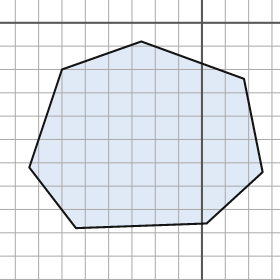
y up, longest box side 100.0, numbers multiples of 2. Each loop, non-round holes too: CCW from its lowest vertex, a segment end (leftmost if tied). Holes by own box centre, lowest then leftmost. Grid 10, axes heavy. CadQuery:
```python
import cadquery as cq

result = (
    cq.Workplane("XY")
    .moveTo(-54.0, -88.0)
    .lineTo(2.0, -86.0)
    .lineTo(26.0, -64.0)
    .lineTo(18.0, -24.0)
    .lineTo(-26.0, -8.0)
    .lineTo(-60.0, -20.0)
    .lineTo(-74.0, -62.0)
    .close()
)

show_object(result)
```